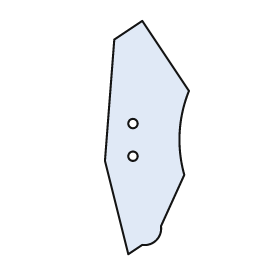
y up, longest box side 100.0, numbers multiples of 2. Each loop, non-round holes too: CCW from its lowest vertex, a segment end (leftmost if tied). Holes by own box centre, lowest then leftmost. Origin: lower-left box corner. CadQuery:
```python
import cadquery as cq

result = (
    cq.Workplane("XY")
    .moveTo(10.0, 0.0)
    .lineTo(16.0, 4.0)
    .threePointArc((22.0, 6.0), (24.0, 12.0))
    .lineTo(34.0, 34.0)
    .threePointArc((32.0, 52.0), (36.0, 70.0))
    .lineTo(16.0, 100.0)
    .lineTo(4.0, 92.0)
    .lineTo(0.0, 40.0)
    .close()
    .moveTo(12.0, 42.0)
    .circle(2.0)
    .moveTo(12.0, 56.0)
    .circle(2.0)
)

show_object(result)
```